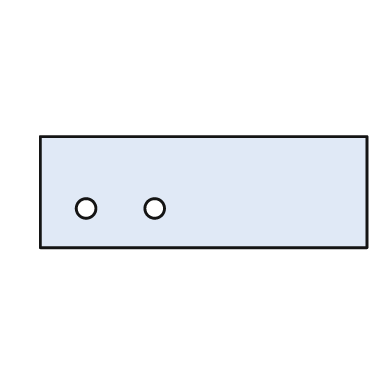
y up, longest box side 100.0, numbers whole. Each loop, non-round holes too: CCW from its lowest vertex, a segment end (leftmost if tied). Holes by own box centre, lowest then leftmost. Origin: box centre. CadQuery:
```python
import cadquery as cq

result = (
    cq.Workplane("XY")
    .moveTo(-50.0, -17.0)
    .lineTo(50.0, -17.0)
    .lineTo(50.0, 17.0)
    .lineTo(-50.0, 17.0)
    .close()
    .moveTo(-36.0, -5.0)
    .circle(3.0)
    .moveTo(-15.0, -5.0)
    .circle(3.0)
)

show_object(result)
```